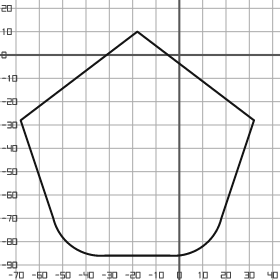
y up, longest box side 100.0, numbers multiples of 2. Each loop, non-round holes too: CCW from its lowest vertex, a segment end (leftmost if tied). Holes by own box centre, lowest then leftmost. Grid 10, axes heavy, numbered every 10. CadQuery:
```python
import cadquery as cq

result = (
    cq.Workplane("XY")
    .moveTo(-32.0, -86.0)
    .lineTo(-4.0, -86.0)
    .threePointArc((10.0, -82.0), (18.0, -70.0))
    .lineTo(32.0, -28.0)
    .lineTo(-18.0, 10.0)
    .lineTo(-68.0, -28.0)
    .lineTo(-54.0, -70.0)
    .threePointArc((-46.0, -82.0), (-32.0, -86.0))
    .close()
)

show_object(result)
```